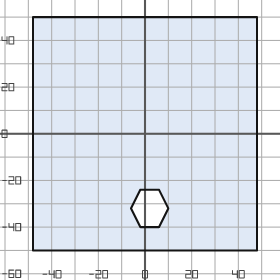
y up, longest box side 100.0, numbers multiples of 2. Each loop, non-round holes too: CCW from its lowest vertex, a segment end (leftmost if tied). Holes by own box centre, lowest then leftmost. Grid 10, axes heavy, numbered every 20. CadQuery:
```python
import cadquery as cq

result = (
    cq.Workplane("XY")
    .moveTo(-48.0, -50.0)
    .lineTo(48.0, -50.0)
    .lineTo(48.0, 50.0)
    .lineTo(-48.0, 50.0)
    .close()
    .moveTo(-2.0, -40.0)
    .lineTo(6.0, -40.0)
    .lineTo(10.0, -32.0)
    .lineTo(6.0, -24.0)
    .lineTo(-2.0, -24.0)
    .lineTo(-6.0, -32.0)
    .close()
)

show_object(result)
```